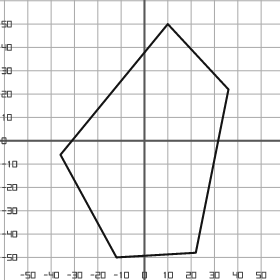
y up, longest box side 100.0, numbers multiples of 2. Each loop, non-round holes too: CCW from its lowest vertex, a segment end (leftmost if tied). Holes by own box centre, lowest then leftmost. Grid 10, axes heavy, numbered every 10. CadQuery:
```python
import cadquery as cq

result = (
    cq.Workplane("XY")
    .moveTo(-12.0, -50.0)
    .lineTo(22.0, -48.0)
    .lineTo(36.0, 22.0)
    .lineTo(10.0, 50.0)
    .lineTo(-36.0, -6.0)
    .close()
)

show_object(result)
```